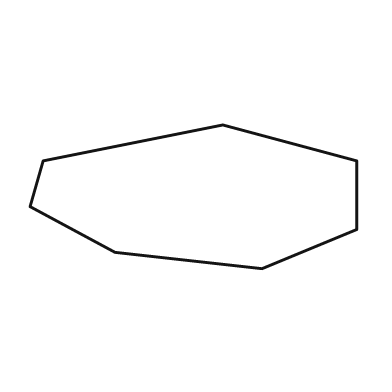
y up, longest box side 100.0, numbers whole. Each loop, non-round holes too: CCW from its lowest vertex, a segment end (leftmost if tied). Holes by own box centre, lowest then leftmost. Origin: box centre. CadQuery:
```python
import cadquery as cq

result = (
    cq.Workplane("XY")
    .moveTo(21.0, -22.0)
    .lineTo(50.0, -10.0)
    .lineTo(50.0, 11.0)
    .lineTo(9.0, 22.0)
    .lineTo(-46.0, 11.0)
    .lineTo(-50.0, -3.0)
    .lineTo(-24.0, -17.0)
    .close()
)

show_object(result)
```